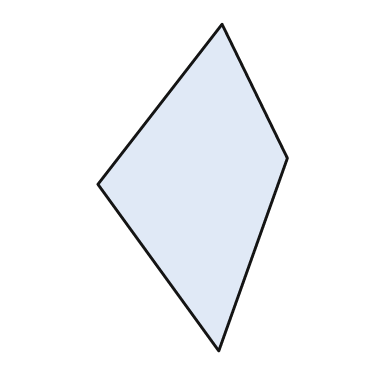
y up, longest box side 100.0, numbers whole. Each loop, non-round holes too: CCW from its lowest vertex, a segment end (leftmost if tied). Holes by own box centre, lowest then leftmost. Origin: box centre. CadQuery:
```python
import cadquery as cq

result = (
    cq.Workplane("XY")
    .moveTo(8.0, -50.0)
    .lineTo(29.0, 9.0)
    .lineTo(9.0, 50.0)
    .lineTo(-29.0, 1.0)
    .close()
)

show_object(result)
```